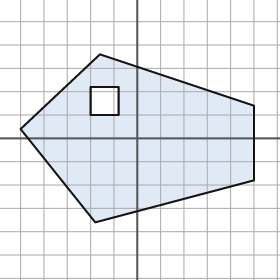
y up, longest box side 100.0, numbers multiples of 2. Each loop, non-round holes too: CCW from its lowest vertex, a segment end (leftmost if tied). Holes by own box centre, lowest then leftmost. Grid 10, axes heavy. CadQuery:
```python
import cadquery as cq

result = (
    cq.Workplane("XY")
    .moveTo(-18.0, -36.0)
    .lineTo(50.0, -18.0)
    .lineTo(50.0, 14.0)
    .lineTo(-16.0, 36.0)
    .lineTo(-50.0, 4.0)
    .close()
    .moveTo(-20.0, 10.0)
    .lineTo(-8.0, 10.0)
    .lineTo(-8.0, 22.0)
    .lineTo(-20.0, 22.0)
    .close()
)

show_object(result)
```